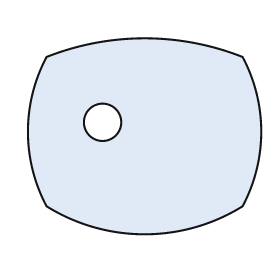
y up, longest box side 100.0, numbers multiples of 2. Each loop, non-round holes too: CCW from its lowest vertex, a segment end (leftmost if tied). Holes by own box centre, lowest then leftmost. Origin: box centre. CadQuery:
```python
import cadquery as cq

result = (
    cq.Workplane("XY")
    .moveTo(-42.0, -30.0)
    .threePointArc((0.0, -42.0), (42.0, -30.0))
    .threePointArc((50.0, 2.0), (42.0, 34.0))
    .threePointArc((0.0, 42.0), (-42.0, 34.0))
    .threePointArc((-50.0, 2.0), (-42.0, -30.0))
    .close()
    .moveTo(-18.0, 6.0)
    .circle(8.0)
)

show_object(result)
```